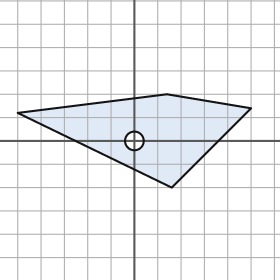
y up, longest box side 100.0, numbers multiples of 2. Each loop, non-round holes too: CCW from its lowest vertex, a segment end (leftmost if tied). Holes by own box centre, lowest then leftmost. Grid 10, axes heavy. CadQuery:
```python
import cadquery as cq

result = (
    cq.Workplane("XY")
    .moveTo(16.0, -20.0)
    .lineTo(50.0, 14.0)
    .lineTo(14.0, 20.0)
    .lineTo(-50.0, 12.0)
    .close()
    .moveTo(0.0, 0.0)
    .circle(4.0)
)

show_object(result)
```